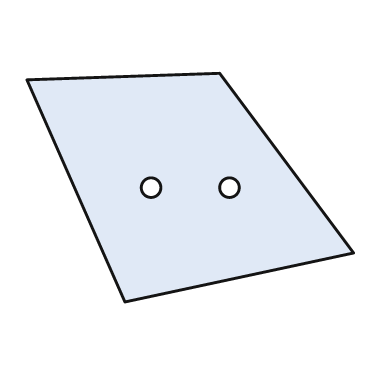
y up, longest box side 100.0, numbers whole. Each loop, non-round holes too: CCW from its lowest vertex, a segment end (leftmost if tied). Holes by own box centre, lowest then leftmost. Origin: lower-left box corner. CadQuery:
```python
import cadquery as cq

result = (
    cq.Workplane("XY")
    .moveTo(30.0, 0.0)
    .lineTo(100.0, 15.0)
    .lineTo(59.0, 70.0)
    .lineTo(0.0, 68.0)
    .close()
    .moveTo(38.0, 35.0)
    .circle(3.0)
    .moveTo(62.0, 35.0)
    .circle(3.0)
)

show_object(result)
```